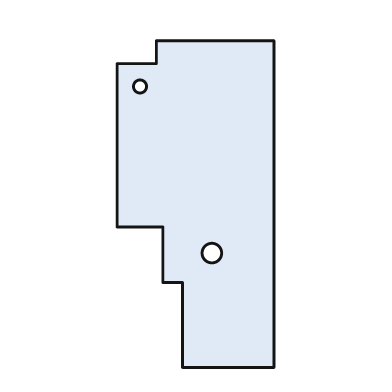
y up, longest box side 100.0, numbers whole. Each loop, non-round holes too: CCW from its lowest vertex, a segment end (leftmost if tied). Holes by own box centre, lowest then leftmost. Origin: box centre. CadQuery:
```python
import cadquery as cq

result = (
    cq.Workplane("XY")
    .moveTo(-4.0, -50.0)
    .lineTo(24.0, -50.0)
    .lineTo(24.0, 50.0)
    .lineTo(-12.0, 50.0)
    .lineTo(-12.0, 43.0)
    .lineTo(-24.0, 43.0)
    .lineTo(-24.0, -7.0)
    .lineTo(-10.0, -7.0)
    .lineTo(-10.0, -24.0)
    .lineTo(-4.0, -24.0)
    .close()
    .moveTo(5.0, -15.0)
    .circle(3.0)
    .moveTo(-17.0, 36.0)
    .circle(2.0)
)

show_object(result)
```